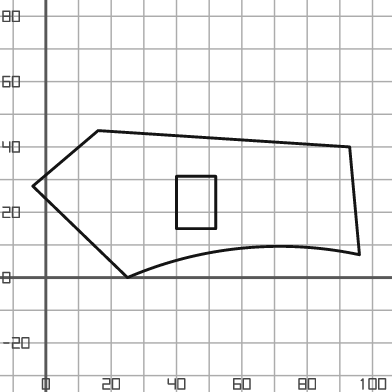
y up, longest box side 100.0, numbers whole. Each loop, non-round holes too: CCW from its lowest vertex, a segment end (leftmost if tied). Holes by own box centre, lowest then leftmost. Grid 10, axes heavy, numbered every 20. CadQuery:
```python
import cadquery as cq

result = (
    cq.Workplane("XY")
    .moveTo(25.0, 0.0)
    .threePointArc((60.0, 9.0), (96.0, 7.0))
    .lineTo(93.0, 40.0)
    .lineTo(16.0, 45.0)
    .lineTo(-4.0, 28.0)
    .close()
    .moveTo(40.0, 15.0)
    .lineTo(52.0, 15.0)
    .lineTo(52.0, 31.0)
    .lineTo(40.0, 31.0)
    .close()
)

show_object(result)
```